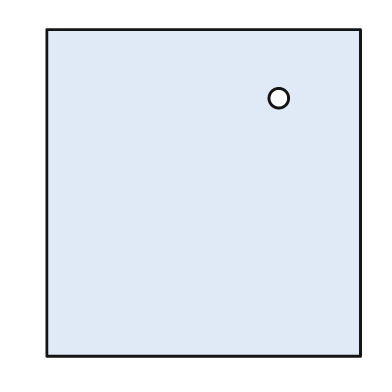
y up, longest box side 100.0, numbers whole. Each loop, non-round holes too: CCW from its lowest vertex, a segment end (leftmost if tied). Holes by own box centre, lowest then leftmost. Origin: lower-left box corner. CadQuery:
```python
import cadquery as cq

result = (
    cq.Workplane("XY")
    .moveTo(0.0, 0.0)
    .lineTo(96.0, 0.0)
    .lineTo(96.0, 100.0)
    .lineTo(0.0, 100.0)
    .close()
    .moveTo(71.0, 79.0)
    .circle(3.0)
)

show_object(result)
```